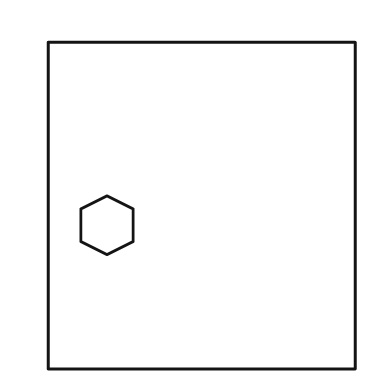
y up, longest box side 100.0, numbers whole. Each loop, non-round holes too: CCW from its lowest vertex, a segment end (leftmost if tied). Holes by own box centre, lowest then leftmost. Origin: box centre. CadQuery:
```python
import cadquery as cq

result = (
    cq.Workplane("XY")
    .moveTo(-47.0, -50.0)
    .lineTo(47.0, -50.0)
    .lineTo(47.0, 50.0)
    .lineTo(-47.0, 50.0)
    .close()
    .moveTo(-29.0, -15.0)
    .lineTo(-21.0, -11.0)
    .lineTo(-21.0, -1.0)
    .lineTo(-29.0, 3.0)
    .lineTo(-37.0, -1.0)
    .lineTo(-37.0, -11.0)
    .close()
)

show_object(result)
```